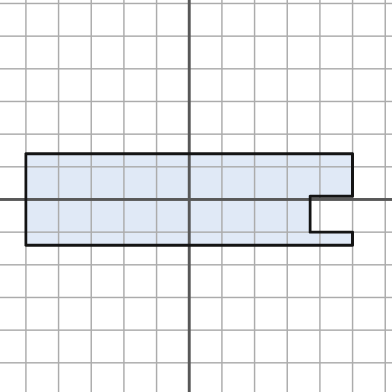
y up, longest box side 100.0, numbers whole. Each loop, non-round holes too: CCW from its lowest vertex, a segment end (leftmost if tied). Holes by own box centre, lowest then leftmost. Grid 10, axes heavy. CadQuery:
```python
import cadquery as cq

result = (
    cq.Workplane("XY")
    .moveTo(-50.0, -14.0)
    .lineTo(50.0, -14.0)
    .lineTo(50.0, -10.0)
    .lineTo(37.0, -10.0)
    .lineTo(37.0, 1.0)
    .lineTo(50.0, 1.0)
    .lineTo(50.0, 14.0)
    .lineTo(-50.0, 14.0)
    .close()
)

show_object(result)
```